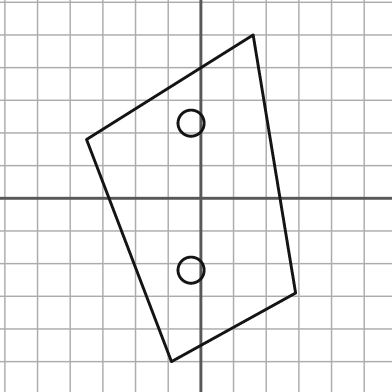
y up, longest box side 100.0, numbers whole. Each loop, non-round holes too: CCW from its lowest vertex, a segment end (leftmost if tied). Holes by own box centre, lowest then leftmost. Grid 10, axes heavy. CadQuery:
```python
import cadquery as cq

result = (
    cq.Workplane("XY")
    .moveTo(-9.0, -50.0)
    .lineTo(29.0, -29.0)
    .lineTo(16.0, 50.0)
    .lineTo(-35.0, 18.0)
    .close()
    .moveTo(-3.0, -22.0)
    .circle(4.0)
    .moveTo(-3.0, 23.0)
    .circle(4.0)
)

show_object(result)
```